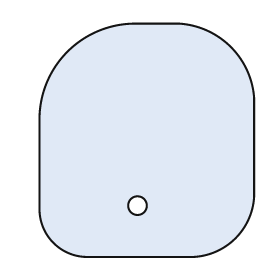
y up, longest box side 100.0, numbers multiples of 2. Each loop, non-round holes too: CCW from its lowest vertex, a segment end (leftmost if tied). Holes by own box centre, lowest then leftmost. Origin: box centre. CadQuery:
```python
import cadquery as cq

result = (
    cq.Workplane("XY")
    .moveTo(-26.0, -50.0)
    .lineTo(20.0, -50.0)
    .threePointArc((38.0, -42.0), (46.0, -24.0))
    .lineTo(46.0, 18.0)
    .threePointArc((36.0, 40.0), (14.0, 50.0))
    .lineTo(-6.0, 50.0)
    .threePointArc((-34.0, 38.0), (-46.0, 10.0))
    .lineTo(-46.0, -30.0)
    .threePointArc((-40.0, -44.0), (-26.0, -50.0))
    .close()
    .moveTo(-4.0, -28.0)
    .circle(4.0)
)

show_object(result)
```